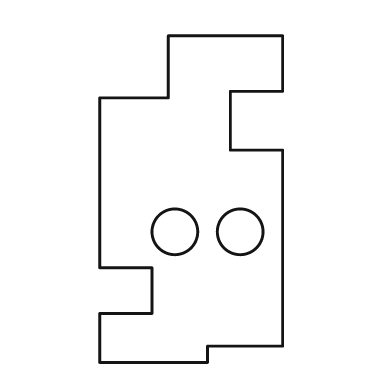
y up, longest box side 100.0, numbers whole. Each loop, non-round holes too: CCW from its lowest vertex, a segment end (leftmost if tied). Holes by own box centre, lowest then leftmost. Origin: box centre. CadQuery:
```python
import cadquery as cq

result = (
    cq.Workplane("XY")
    .moveTo(-28.0, -50.0)
    .lineTo(5.0, -50.0)
    .lineTo(5.0, -45.0)
    .lineTo(28.0, -45.0)
    .lineTo(28.0, 15.0)
    .lineTo(12.0, 15.0)
    .lineTo(12.0, 33.0)
    .lineTo(28.0, 33.0)
    .lineTo(28.0, 50.0)
    .lineTo(-7.0, 50.0)
    .lineTo(-7.0, 31.0)
    .lineTo(-28.0, 31.0)
    .lineTo(-28.0, -21.0)
    .lineTo(-12.0, -21.0)
    .lineTo(-12.0, -35.0)
    .lineTo(-28.0, -35.0)
    .close()
    .moveTo(-5.0, -10.0)
    .circle(7.0)
    .moveTo(15.0, -10.0)
    .circle(7.0)
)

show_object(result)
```